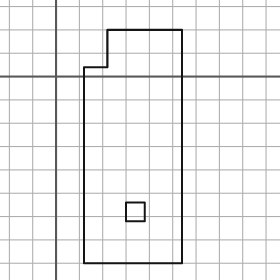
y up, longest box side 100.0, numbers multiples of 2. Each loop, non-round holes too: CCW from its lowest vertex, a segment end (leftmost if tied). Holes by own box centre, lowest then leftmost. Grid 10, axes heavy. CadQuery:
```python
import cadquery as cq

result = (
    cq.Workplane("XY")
    .moveTo(12.0, -80.0)
    .lineTo(54.0, -80.0)
    .lineTo(54.0, 20.0)
    .lineTo(22.0, 20.0)
    .lineTo(22.0, 4.0)
    .lineTo(12.0, 4.0)
    .close()
    .moveTo(30.0, -62.0)
    .lineTo(38.0, -62.0)
    .lineTo(38.0, -54.0)
    .lineTo(30.0, -54.0)
    .close()
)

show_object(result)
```